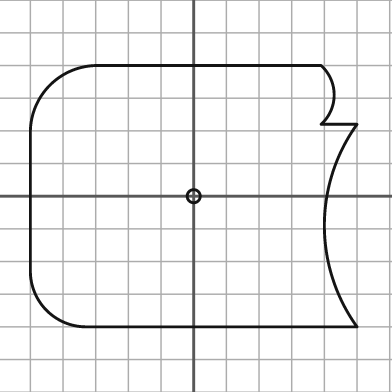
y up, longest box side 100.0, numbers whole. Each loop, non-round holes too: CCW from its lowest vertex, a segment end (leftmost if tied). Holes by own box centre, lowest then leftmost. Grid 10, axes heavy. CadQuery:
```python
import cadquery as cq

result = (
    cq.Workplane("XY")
    .moveTo(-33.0, -40.0)
    .lineTo(50.0, -40.0)
    .threePointArc((40.0, -9.0), (50.0, 22.0))
    .lineTo(39.0, 22.0)
    .threePointArc((43.0, 31.0), (39.0, 40.0))
    .lineTo(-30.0, 40.0)
    .threePointArc((-44.0, 34.0), (-50.0, 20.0))
    .lineTo(-50.0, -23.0)
    .threePointArc((-45.0, -35.0), (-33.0, -40.0))
    .close()
    .moveTo(0.0, 0.0)
    .circle(2.0)
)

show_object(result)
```